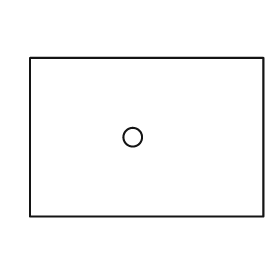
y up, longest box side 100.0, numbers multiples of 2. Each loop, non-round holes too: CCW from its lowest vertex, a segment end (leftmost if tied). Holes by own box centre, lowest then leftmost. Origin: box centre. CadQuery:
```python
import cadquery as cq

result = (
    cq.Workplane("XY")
    .moveTo(-50.0, -34.0)
    .lineTo(50.0, -34.0)
    .lineTo(50.0, 34.0)
    .lineTo(-50.0, 34.0)
    .close()
    .moveTo(-6.0, 0.0)
    .circle(4.0)
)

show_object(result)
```